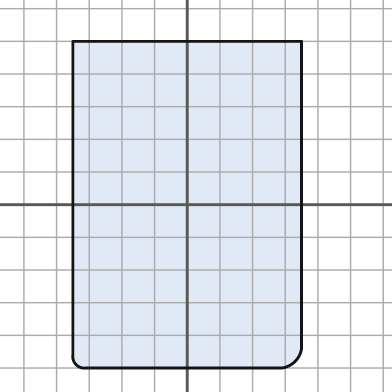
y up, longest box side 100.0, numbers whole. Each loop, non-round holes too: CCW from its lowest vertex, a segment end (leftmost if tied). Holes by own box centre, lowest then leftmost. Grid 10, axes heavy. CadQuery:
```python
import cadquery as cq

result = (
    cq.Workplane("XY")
    .moveTo(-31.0, -50.0)
    .lineTo(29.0, -50.0)
    .threePointArc((33.0, -48.0), (35.0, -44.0))
    .lineTo(35.0, 50.0)
    .lineTo(-35.0, 50.0)
    .lineTo(-35.0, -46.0)
    .threePointArc((-34.0, -49.0), (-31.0, -50.0))
    .close()
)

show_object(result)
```